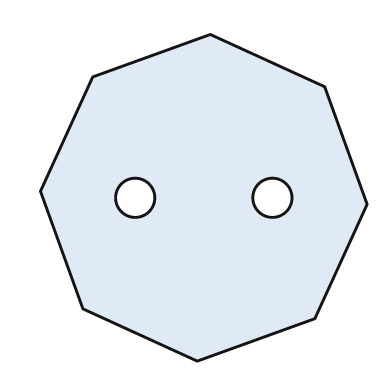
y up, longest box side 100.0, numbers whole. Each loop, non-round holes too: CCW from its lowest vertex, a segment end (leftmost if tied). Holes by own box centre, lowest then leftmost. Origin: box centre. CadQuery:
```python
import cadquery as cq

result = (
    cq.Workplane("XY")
    .moveTo(-2.0, -50.0)
    .lineTo(34.0, -37.0)
    .lineTo(50.0, -2.0)
    .lineTo(37.0, 34.0)
    .lineTo(2.0, 50.0)
    .lineTo(-34.0, 37.0)
    .lineTo(-50.0, 2.0)
    .lineTo(-37.0, -34.0)
    .close()
    .moveTo(-21.0, 0.0)
    .circle(6.0)
    .moveTo(21.0, 0.0)
    .circle(6.0)
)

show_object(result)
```